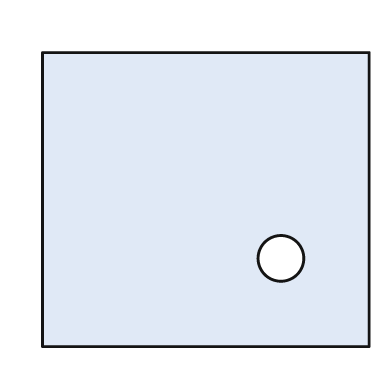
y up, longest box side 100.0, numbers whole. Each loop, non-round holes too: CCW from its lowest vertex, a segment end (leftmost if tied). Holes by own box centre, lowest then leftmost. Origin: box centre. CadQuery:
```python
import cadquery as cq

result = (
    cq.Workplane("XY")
    .moveTo(-50.0, -45.0)
    .lineTo(50.0, -45.0)
    .lineTo(50.0, 45.0)
    .lineTo(-50.0, 45.0)
    .close()
    .moveTo(23.0, -18.0)
    .circle(7.0)
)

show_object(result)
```